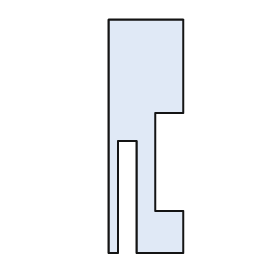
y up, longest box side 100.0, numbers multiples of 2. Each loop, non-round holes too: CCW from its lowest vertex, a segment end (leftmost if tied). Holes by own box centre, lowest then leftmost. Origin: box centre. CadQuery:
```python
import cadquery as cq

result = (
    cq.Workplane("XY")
    .moveTo(-16.0, -50.0)
    .lineTo(-12.0, -50.0)
    .lineTo(-12.0, -2.0)
    .lineTo(-4.0, -2.0)
    .lineTo(-4.0, -50.0)
    .lineTo(16.0, -50.0)
    .lineTo(16.0, -32.0)
    .lineTo(4.0, -32.0)
    .lineTo(4.0, 10.0)
    .lineTo(16.0, 10.0)
    .lineTo(16.0, 50.0)
    .lineTo(-16.0, 50.0)
    .close()
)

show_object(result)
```